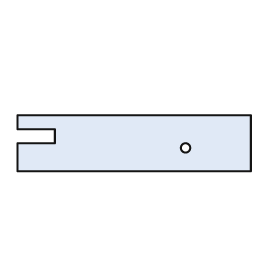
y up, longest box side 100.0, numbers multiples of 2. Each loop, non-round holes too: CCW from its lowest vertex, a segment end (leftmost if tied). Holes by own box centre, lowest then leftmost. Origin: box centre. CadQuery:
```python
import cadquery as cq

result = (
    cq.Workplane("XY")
    .moveTo(-50.0, -12.0)
    .lineTo(50.0, -12.0)
    .lineTo(50.0, 12.0)
    .lineTo(-50.0, 12.0)
    .lineTo(-50.0, 6.0)
    .lineTo(-34.0, 6.0)
    .lineTo(-34.0, 0.0)
    .lineTo(-50.0, 0.0)
    .close()
    .moveTo(22.0, -2.0)
    .circle(2.0)
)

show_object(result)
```